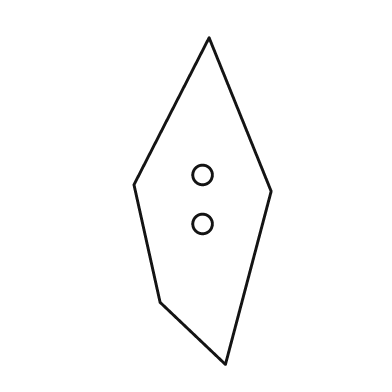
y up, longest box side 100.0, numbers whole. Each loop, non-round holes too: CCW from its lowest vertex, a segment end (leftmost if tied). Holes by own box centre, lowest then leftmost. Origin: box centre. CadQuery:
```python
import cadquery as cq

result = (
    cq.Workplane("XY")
    .moveTo(7.0, -50.0)
    .lineTo(21.0, 3.0)
    .lineTo(2.0, 50.0)
    .lineTo(-21.0, 5.0)
    .lineTo(-13.0, -31.0)
    .close()
    .moveTo(0.0, -7.0)
    .circle(3.0)
    .moveTo(0.0, 8.0)
    .circle(3.0)
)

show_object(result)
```